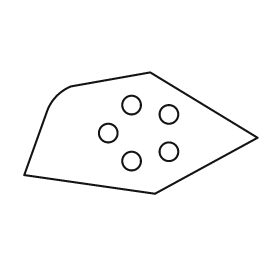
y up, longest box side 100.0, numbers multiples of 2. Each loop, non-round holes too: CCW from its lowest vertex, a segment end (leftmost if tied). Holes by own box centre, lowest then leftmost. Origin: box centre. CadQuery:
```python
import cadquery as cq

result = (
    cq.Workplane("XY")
    .moveTo(6.0, -26.0)
    .lineTo(50.0, -2.0)
    .lineTo(4.0, 26.0)
    .lineTo(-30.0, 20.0)
    .threePointArc((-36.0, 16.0), (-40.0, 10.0))
    .lineTo(-50.0, -18.0)
    .close()
    .moveTo(-4.0, -12.0)
    .circle(4.0)
    .moveTo(12.0, -8.0)
    .circle(4.0)
    .moveTo(-14.0, 0.0)
    .circle(4.0)
    .moveTo(12.0, 8.0)
    .circle(4.0)
    .moveTo(-4.0, 12.0)
    .circle(4.0)
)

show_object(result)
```